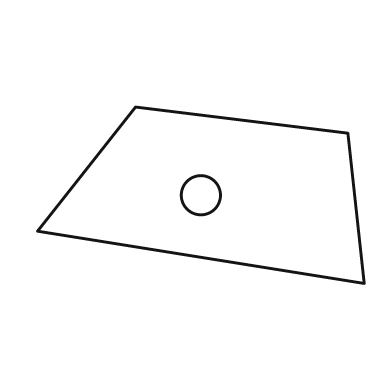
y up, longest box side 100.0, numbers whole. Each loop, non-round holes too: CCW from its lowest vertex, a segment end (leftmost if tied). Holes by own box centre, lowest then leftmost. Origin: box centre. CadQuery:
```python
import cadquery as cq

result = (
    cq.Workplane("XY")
    .moveTo(50.0, -27.0)
    .lineTo(45.0, 19.0)
    .lineTo(-20.0, 27.0)
    .lineTo(-50.0, -11.0)
    .close()
    .moveTo(0.0, 0.0)
    .circle(6.0)
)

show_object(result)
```